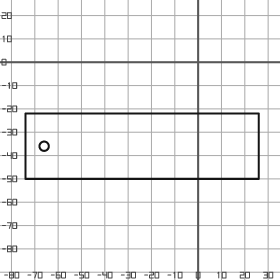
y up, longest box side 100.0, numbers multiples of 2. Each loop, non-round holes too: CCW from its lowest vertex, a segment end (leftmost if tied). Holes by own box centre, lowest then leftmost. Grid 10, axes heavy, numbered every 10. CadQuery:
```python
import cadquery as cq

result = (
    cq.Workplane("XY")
    .moveTo(-74.0, -50.0)
    .lineTo(26.0, -50.0)
    .lineTo(26.0, -22.0)
    .lineTo(-74.0, -22.0)
    .close()
    .moveTo(-66.0, -36.0)
    .circle(2.0)
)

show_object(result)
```